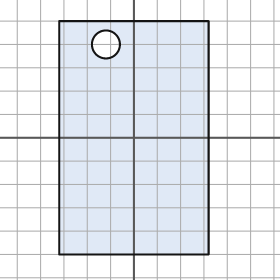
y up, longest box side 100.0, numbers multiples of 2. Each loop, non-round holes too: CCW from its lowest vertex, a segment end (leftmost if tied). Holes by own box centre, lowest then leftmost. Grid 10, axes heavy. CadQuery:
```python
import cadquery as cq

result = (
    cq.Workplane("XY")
    .moveTo(-32.0, -50.0)
    .lineTo(32.0, -50.0)
    .lineTo(32.0, 50.0)
    .lineTo(-32.0, 50.0)
    .close()
    .moveTo(-12.0, 40.0)
    .circle(6.0)
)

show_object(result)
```